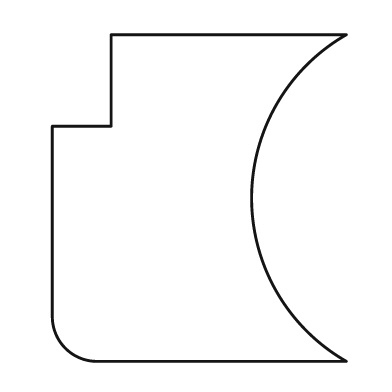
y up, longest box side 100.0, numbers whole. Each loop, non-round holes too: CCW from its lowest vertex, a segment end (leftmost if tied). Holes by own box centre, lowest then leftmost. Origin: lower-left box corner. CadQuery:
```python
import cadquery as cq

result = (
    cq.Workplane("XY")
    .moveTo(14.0, 0.0)
    .lineTo(90.0, 0.0)
    .threePointArc((61.0, 50.0), (90.0, 100.0))
    .lineTo(18.0, 100.0)
    .lineTo(18.0, 72.0)
    .lineTo(0.0, 72.0)
    .lineTo(0.0, 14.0)
    .threePointArc((4.0, 4.0), (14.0, 0.0))
    .close()
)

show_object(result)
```